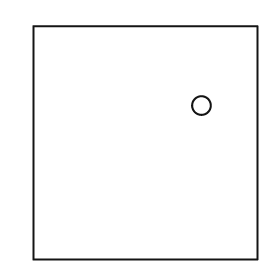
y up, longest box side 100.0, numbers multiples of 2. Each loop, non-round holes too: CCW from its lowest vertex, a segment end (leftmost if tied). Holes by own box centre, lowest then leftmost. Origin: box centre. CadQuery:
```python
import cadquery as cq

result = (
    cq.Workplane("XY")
    .moveTo(-48.0, -50.0)
    .lineTo(48.0, -50.0)
    .lineTo(48.0, 50.0)
    .lineTo(-48.0, 50.0)
    .close()
    .moveTo(24.0, 16.0)
    .circle(4.0)
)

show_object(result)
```